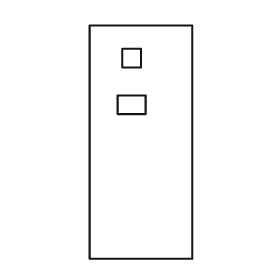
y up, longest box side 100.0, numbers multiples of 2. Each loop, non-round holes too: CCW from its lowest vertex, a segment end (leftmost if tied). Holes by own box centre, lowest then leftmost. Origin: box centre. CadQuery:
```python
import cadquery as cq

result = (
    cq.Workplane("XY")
    .moveTo(-22.0, -50.0)
    .lineTo(22.0, -50.0)
    .lineTo(22.0, 50.0)
    .lineTo(-22.0, 50.0)
    .close()
    .moveTo(-10.0, 12.0)
    .lineTo(2.0, 12.0)
    .lineTo(2.0, 20.0)
    .lineTo(-10.0, 20.0)
    .close()
    .moveTo(-8.0, 32.0)
    .lineTo(0.0, 32.0)
    .lineTo(0.0, 40.0)
    .lineTo(-8.0, 40.0)
    .close()
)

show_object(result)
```